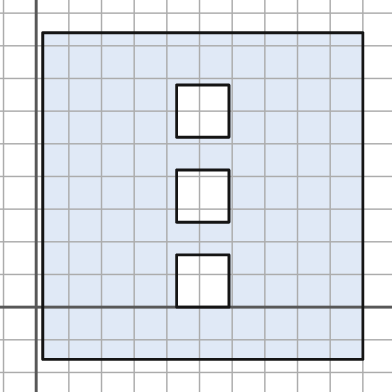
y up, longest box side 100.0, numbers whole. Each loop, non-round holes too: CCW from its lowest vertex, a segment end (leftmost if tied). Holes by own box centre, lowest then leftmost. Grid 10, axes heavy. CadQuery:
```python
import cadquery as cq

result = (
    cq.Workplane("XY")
    .moveTo(2.0, -16.0)
    .lineTo(100.0, -16.0)
    .lineTo(100.0, 84.0)
    .lineTo(2.0, 84.0)
    .close()
    .moveTo(43.0, 0.0)
    .lineTo(59.0, 0.0)
    .lineTo(59.0, 16.0)
    .lineTo(43.0, 16.0)
    .close()
    .moveTo(43.0, 26.0)
    .lineTo(59.0, 26.0)
    .lineTo(59.0, 42.0)
    .lineTo(43.0, 42.0)
    .close()
    .moveTo(43.0, 52.0)
    .lineTo(59.0, 52.0)
    .lineTo(59.0, 68.0)
    .lineTo(43.0, 68.0)
    .close()
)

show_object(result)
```